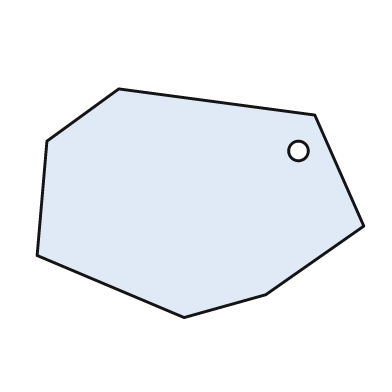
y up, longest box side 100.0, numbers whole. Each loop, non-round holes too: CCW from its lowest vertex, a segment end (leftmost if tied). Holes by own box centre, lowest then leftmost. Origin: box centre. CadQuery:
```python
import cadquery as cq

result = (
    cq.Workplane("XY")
    .moveTo(-5.0, -35.0)
    .lineTo(20.0, -28.0)
    .lineTo(50.0, -7.0)
    .lineTo(35.0, 27.0)
    .lineTo(-25.0, 35.0)
    .lineTo(-47.0, 19.0)
    .lineTo(-50.0, -16.0)
    .close()
    .moveTo(30.0, 16.0)
    .circle(3.0)
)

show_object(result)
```